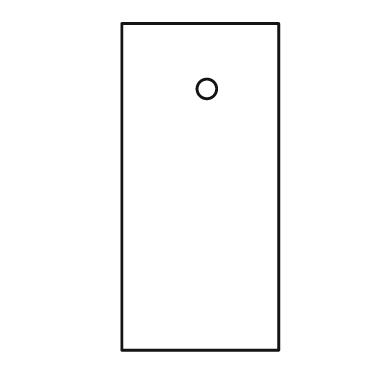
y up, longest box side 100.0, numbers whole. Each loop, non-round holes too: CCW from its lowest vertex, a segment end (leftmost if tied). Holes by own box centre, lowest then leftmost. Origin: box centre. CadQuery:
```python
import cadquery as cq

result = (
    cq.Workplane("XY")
    .moveTo(-24.0, -50.0)
    .lineTo(24.0, -50.0)
    .lineTo(24.0, 50.0)
    .lineTo(-24.0, 50.0)
    .close()
    .moveTo(2.0, 30.0)
    .circle(3.0)
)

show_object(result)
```